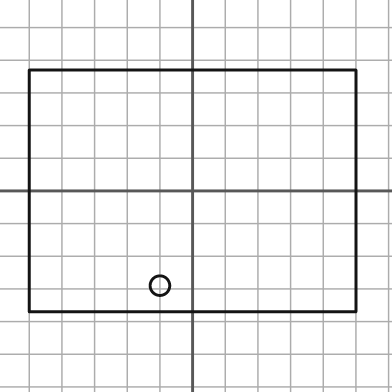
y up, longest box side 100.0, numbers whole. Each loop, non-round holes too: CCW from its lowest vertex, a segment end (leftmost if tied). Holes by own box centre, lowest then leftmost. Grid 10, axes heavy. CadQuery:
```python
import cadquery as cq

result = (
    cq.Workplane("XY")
    .moveTo(-50.0, -37.0)
    .lineTo(50.0, -37.0)
    .lineTo(50.0, 37.0)
    .lineTo(-50.0, 37.0)
    .close()
    .moveTo(-10.0, -29.0)
    .circle(3.0)
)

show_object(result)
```